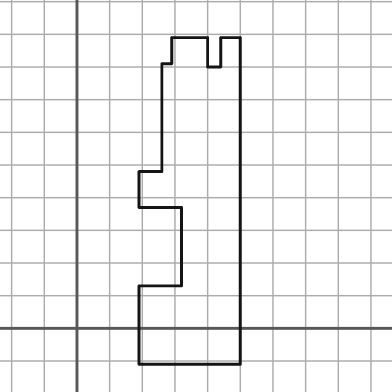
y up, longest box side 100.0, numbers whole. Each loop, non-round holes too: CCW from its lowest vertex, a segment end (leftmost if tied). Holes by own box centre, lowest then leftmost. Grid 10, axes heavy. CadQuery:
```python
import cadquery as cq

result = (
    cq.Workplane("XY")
    .moveTo(19.0, -11.0)
    .lineTo(50.0, -11.0)
    .lineTo(50.0, 89.0)
    .lineTo(44.0, 89.0)
    .lineTo(44.0, 80.0)
    .lineTo(40.0, 80.0)
    .lineTo(40.0, 89.0)
    .lineTo(29.0, 89.0)
    .lineTo(29.0, 81.0)
    .lineTo(26.0, 81.0)
    .lineTo(26.0, 48.0)
    .lineTo(19.0, 48.0)
    .lineTo(19.0, 37.0)
    .lineTo(32.0, 37.0)
    .lineTo(32.0, 13.0)
    .lineTo(19.0, 13.0)
    .close()
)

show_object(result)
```